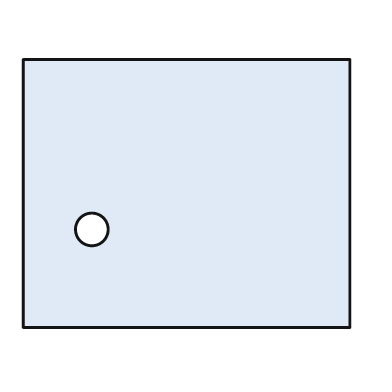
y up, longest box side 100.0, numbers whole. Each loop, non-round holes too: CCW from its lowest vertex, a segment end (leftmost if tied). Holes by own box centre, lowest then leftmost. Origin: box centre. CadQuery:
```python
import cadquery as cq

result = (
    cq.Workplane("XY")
    .moveTo(-50.0, -41.0)
    .lineTo(50.0, -41.0)
    .lineTo(50.0, 41.0)
    .lineTo(-50.0, 41.0)
    .close()
    .moveTo(-29.0, -11.0)
    .circle(5.0)
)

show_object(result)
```